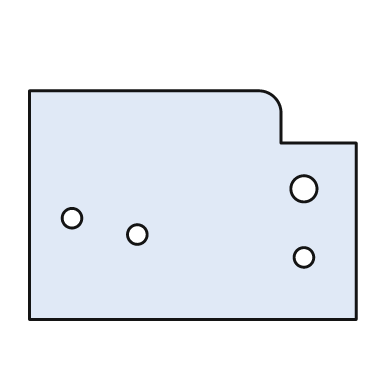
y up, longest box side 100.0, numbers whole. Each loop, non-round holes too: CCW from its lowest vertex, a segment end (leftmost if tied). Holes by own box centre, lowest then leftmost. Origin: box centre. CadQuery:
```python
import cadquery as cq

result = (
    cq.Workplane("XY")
    .moveTo(-50.0, -35.0)
    .lineTo(50.0, -35.0)
    .lineTo(50.0, 19.0)
    .lineTo(27.0, 19.0)
    .lineTo(27.0, 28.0)
    .threePointArc((25.0, 33.0), (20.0, 35.0))
    .lineTo(-50.0, 35.0)
    .close()
    .moveTo(34.0, -16.0)
    .circle(3.0)
    .moveTo(-17.0, -9.0)
    .circle(3.0)
    .moveTo(-37.0, -4.0)
    .circle(3.0)
    .moveTo(34.0, 5.0)
    .circle(4.0)
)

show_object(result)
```